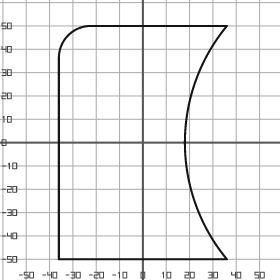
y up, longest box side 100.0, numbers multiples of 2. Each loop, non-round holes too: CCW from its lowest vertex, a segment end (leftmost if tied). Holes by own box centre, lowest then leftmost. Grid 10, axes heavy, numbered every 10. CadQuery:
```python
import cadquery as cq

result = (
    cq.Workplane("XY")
    .moveTo(-36.0, -50.0)
    .lineTo(36.0, -50.0)
    .threePointArc((18.0, 0.0), (36.0, 50.0))
    .lineTo(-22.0, 50.0)
    .threePointArc((-32.0, 46.0), (-36.0, 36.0))
    .close()
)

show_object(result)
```